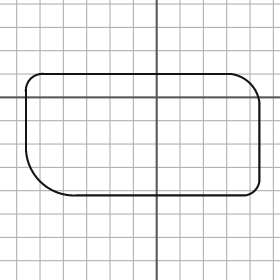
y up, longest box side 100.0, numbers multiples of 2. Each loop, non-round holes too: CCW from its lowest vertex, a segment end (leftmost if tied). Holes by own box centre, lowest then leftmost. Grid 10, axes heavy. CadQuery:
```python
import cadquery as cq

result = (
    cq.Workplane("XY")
    .moveTo(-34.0, -42.0)
    .lineTo(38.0, -42.0)
    .threePointArc((42.0, -40.0), (44.0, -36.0))
    .lineTo(44.0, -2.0)
    .threePointArc((40.0, 6.0), (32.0, 10.0))
    .lineTo(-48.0, 10.0)
    .threePointArc((-54.0, 8.0), (-56.0, 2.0))
    .lineTo(-56.0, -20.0)
    .threePointArc((-50.0, -36.0), (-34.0, -42.0))
    .close()
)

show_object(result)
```